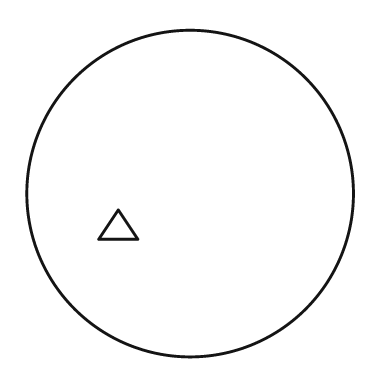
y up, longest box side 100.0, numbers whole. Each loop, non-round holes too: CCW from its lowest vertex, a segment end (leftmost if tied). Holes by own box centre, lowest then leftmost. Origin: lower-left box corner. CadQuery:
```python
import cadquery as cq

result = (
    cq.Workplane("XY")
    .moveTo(50.0, 50.0)
    .circle(50.0)
    .moveTo(22.0, 36.0)
    .lineTo(34.0, 36.0)
    .lineTo(28.0, 45.0)
    .close()
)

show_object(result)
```